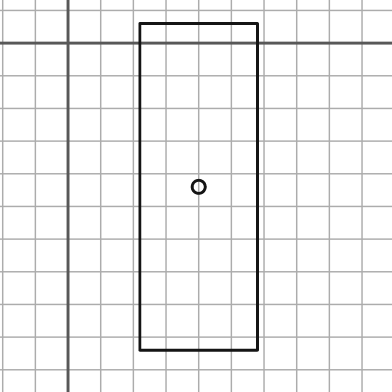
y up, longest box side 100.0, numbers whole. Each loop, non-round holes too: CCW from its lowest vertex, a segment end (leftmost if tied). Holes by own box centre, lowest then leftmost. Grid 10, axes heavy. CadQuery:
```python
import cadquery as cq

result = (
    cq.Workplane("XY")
    .moveTo(22.0, -94.0)
    .lineTo(58.0, -94.0)
    .lineTo(58.0, 6.0)
    .lineTo(22.0, 6.0)
    .close()
    .moveTo(40.0, -44.0)
    .circle(2.0)
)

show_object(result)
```